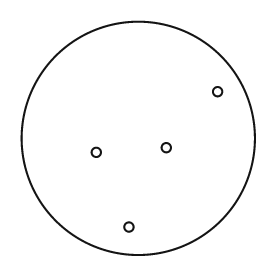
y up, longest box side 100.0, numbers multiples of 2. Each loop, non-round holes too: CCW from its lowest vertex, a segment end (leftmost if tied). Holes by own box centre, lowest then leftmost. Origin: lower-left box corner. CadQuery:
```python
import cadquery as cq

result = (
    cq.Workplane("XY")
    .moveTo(50.0, 50.0)
    .circle(50.0)
    .moveTo(46.0, 12.0)
    .circle(2.0)
    .moveTo(32.0, 44.0)
    .circle(2.0)
    .moveTo(62.0, 46.0)
    .circle(2.0)
    .moveTo(84.0, 70.0)
    .circle(2.0)
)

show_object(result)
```